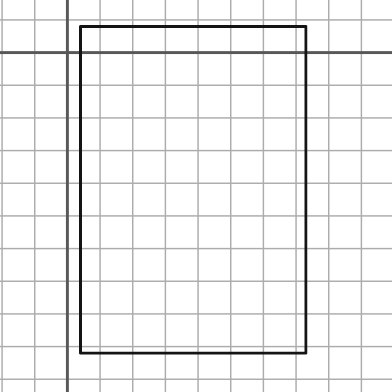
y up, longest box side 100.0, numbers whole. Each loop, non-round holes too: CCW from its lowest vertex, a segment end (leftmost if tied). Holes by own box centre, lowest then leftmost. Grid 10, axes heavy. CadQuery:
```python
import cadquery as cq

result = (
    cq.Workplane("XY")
    .moveTo(4.0, -92.0)
    .lineTo(73.0, -92.0)
    .lineTo(73.0, 8.0)
    .lineTo(4.0, 8.0)
    .close()
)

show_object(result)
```